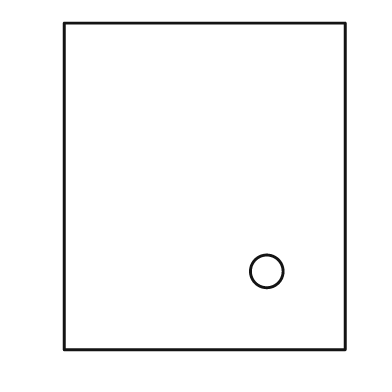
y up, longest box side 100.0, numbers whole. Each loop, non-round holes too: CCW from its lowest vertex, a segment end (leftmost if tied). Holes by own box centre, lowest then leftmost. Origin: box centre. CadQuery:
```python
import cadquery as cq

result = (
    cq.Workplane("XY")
    .moveTo(-43.0, -50.0)
    .lineTo(43.0, -50.0)
    .lineTo(43.0, 50.0)
    .lineTo(-43.0, 50.0)
    .close()
    .moveTo(19.0, -26.0)
    .circle(5.0)
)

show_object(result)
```